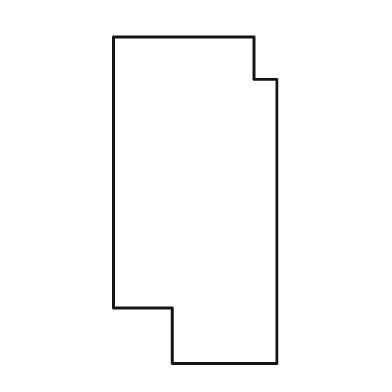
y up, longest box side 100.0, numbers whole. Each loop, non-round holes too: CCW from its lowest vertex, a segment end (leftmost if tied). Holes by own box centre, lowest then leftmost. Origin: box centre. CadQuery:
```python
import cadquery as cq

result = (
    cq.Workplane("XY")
    .moveTo(-7.0, -50.0)
    .lineTo(25.0, -50.0)
    .lineTo(25.0, 37.0)
    .lineTo(18.0, 37.0)
    .lineTo(18.0, 50.0)
    .lineTo(-25.0, 50.0)
    .lineTo(-25.0, -33.0)
    .lineTo(-7.0, -33.0)
    .close()
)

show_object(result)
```